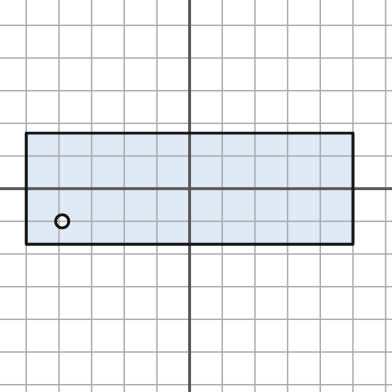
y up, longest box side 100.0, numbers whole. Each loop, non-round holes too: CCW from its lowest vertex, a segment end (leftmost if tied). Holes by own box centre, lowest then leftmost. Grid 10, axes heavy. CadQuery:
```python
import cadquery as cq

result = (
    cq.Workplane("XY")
    .moveTo(-50.0, -17.0)
    .lineTo(50.0, -17.0)
    .lineTo(50.0, 17.0)
    .lineTo(-50.0, 17.0)
    .close()
    .moveTo(-39.0, -10.0)
    .circle(2.0)
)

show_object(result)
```